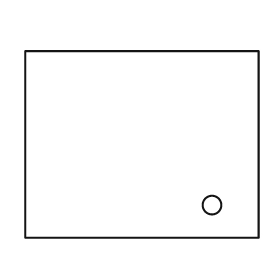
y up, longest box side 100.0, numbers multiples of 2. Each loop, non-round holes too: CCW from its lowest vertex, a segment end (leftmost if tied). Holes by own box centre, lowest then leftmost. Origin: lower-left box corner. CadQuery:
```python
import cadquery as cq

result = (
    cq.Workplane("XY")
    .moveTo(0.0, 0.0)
    .lineTo(100.0, 0.0)
    .lineTo(100.0, 80.0)
    .lineTo(0.0, 80.0)
    .close()
    .moveTo(80.0, 14.0)
    .circle(4.0)
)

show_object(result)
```